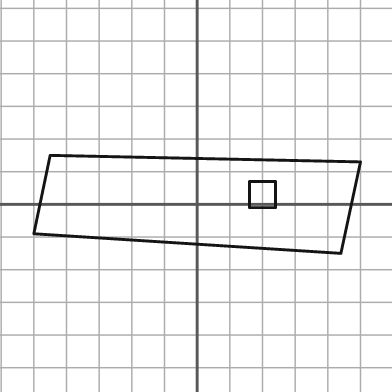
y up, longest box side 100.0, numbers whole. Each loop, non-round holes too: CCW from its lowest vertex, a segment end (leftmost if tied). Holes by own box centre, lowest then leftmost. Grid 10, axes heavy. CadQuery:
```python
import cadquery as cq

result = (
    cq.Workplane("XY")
    .moveTo(44.0, -15.0)
    .lineTo(50.0, 13.0)
    .lineTo(-45.0, 15.0)
    .lineTo(-50.0, -9.0)
    .close()
    .moveTo(16.0, -1.0)
    .lineTo(24.0, -1.0)
    .lineTo(24.0, 7.0)
    .lineTo(16.0, 7.0)
    .close()
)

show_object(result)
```